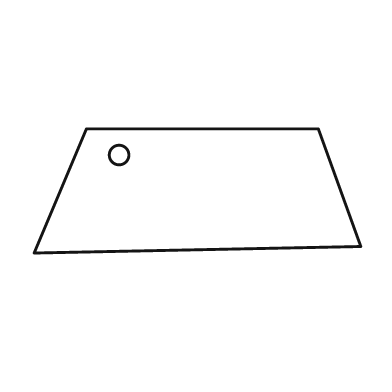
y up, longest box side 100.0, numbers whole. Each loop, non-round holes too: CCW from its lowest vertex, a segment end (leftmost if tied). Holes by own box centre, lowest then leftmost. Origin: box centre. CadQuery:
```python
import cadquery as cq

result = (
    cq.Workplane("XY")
    .moveTo(-50.0, -19.0)
    .lineTo(50.0, -17.0)
    .lineTo(37.0, 19.0)
    .lineTo(-34.0, 19.0)
    .close()
    .moveTo(-24.0, 11.0)
    .circle(3.0)
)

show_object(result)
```